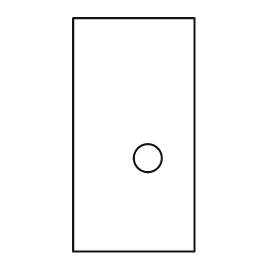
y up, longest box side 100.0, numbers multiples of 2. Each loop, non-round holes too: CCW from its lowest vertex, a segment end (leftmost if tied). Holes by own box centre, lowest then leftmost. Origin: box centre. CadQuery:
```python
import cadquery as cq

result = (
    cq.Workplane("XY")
    .moveTo(-26.0, -50.0)
    .lineTo(26.0, -50.0)
    .lineTo(26.0, 50.0)
    .lineTo(-26.0, 50.0)
    .close()
    .moveTo(6.0, -10.0)
    .circle(6.0)
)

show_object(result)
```